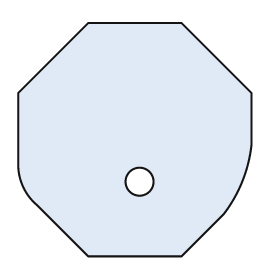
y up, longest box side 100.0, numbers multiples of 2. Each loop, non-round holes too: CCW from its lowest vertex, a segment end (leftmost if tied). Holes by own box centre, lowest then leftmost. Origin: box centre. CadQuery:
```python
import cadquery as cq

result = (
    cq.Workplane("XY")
    .moveTo(-20.0, -50.0)
    .lineTo(20.0, -50.0)
    .lineTo(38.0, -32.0)
    .threePointArc((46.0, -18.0), (50.0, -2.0))
    .lineTo(50.0, 20.0)
    .lineTo(20.0, 50.0)
    .lineTo(-20.0, 50.0)
    .lineTo(-50.0, 20.0)
    .lineTo(-50.0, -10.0)
    .threePointArc((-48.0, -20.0), (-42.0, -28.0))
    .close()
    .moveTo(2.0, -18.0)
    .circle(6.0)
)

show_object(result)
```